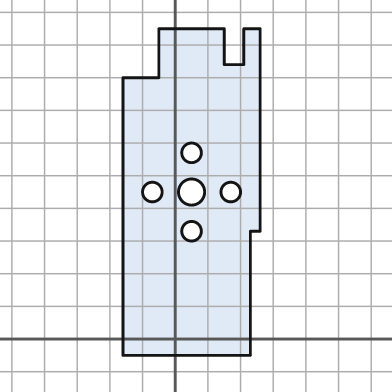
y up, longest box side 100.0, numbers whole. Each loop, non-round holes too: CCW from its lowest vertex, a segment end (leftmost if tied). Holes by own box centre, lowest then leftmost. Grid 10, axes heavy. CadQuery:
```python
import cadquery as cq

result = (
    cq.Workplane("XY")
    .moveTo(-16.0, -5.0)
    .lineTo(23.0, -5.0)
    .lineTo(23.0, 33.0)
    .lineTo(26.0, 33.0)
    .lineTo(26.0, 95.0)
    .lineTo(21.0, 95.0)
    .lineTo(21.0, 84.0)
    .lineTo(15.0, 84.0)
    .lineTo(15.0, 95.0)
    .lineTo(-5.0, 95.0)
    .lineTo(-5.0, 80.0)
    .lineTo(-16.0, 80.0)
    .close()
    .moveTo(5.0, 33.0)
    .circle(3.0)
    .moveTo(-7.0, 45.0)
    .circle(3.0)
    .moveTo(5.0, 45.0)
    .circle(4.0)
    .moveTo(17.0, 45.0)
    .circle(3.0)
    .moveTo(5.0, 57.0)
    .circle(3.0)
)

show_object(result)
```